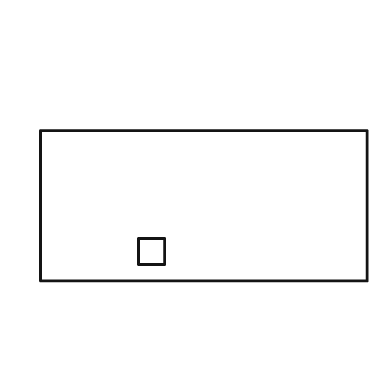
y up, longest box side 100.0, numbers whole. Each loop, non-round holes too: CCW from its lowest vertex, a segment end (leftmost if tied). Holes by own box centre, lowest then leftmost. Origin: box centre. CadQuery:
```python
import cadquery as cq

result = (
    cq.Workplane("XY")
    .moveTo(-50.0, -23.0)
    .lineTo(50.0, -23.0)
    .lineTo(50.0, 23.0)
    .lineTo(-50.0, 23.0)
    .close()
    .moveTo(-20.0, -18.0)
    .lineTo(-12.0, -18.0)
    .lineTo(-12.0, -10.0)
    .lineTo(-20.0, -10.0)
    .close()
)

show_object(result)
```